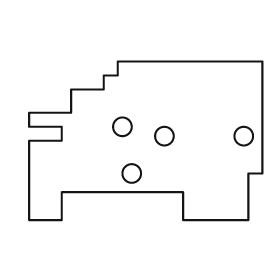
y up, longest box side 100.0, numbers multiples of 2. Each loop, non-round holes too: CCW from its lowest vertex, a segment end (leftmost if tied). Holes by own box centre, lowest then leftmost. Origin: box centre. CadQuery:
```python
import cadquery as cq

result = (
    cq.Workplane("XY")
    .moveTo(-50.0, -34.0)
    .lineTo(-36.0, -34.0)
    .lineTo(-36.0, -22.0)
    .lineTo(16.0, -22.0)
    .lineTo(16.0, -34.0)
    .lineTo(44.0, -34.0)
    .lineTo(44.0, -14.0)
    .lineTo(50.0, -14.0)
    .lineTo(50.0, 34.0)
    .lineTo(-12.0, 34.0)
    .lineTo(-12.0, 28.0)
    .lineTo(-18.0, 28.0)
    .lineTo(-18.0, 22.0)
    .lineTo(-32.0, 22.0)
    .lineTo(-32.0, 12.0)
    .lineTo(-50.0, 12.0)
    .lineTo(-50.0, 6.0)
    .lineTo(-36.0, 6.0)
    .lineTo(-36.0, 0.0)
    .lineTo(-50.0, 0.0)
    .close()
    .moveTo(-6.0, -14.0)
    .circle(4.0)
    .moveTo(8.0, 2.0)
    .circle(4.0)
    .moveTo(42.0, 2.0)
    .circle(4.0)
    .moveTo(-10.0, 6.0)
    .circle(4.0)
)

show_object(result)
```